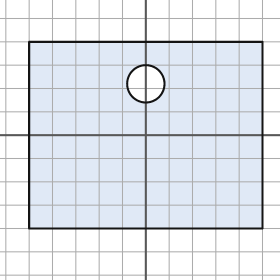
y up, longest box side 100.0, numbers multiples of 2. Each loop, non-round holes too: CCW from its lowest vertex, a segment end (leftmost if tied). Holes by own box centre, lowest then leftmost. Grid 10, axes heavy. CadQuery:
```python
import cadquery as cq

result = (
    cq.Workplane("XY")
    .moveTo(-50.0, -40.0)
    .lineTo(50.0, -40.0)
    .lineTo(50.0, 40.0)
    .lineTo(-50.0, 40.0)
    .close()
    .moveTo(0.0, 22.0)
    .circle(8.0)
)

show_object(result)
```